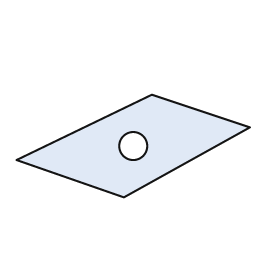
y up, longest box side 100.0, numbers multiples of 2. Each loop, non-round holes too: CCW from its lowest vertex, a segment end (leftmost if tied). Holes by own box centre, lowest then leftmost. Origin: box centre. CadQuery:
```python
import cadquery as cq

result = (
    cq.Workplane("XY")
    .moveTo(-4.0, -22.0)
    .lineTo(50.0, 8.0)
    .lineTo(8.0, 22.0)
    .lineTo(-50.0, -6.0)
    .close()
    .moveTo(0.0, 0.0)
    .circle(6.0)
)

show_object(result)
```